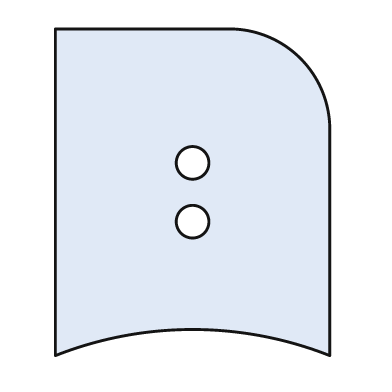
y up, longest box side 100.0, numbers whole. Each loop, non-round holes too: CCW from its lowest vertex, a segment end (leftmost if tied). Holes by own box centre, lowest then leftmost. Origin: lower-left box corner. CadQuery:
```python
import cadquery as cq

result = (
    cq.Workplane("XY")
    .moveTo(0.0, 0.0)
    .threePointArc((42.0, 8.0), (84.0, 0.0))
    .lineTo(84.0, 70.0)
    .threePointArc((75.0, 91.0), (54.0, 100.0))
    .lineTo(0.0, 100.0)
    .close()
    .moveTo(42.0, 41.0)
    .circle(5.0)
    .moveTo(42.0, 59.0)
    .circle(5.0)
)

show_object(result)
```